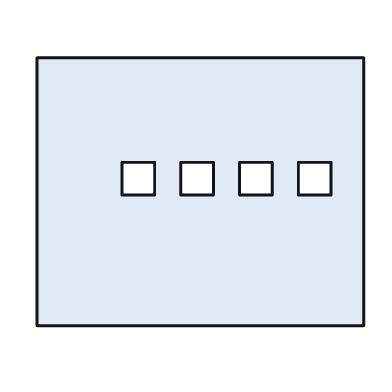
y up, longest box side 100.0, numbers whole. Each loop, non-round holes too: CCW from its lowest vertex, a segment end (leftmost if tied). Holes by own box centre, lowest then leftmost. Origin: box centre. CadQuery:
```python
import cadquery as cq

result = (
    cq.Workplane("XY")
    .moveTo(-50.0, -41.0)
    .lineTo(50.0, -41.0)
    .lineTo(50.0, 41.0)
    .lineTo(-50.0, 41.0)
    .close()
    .moveTo(-24.0, -1.0)
    .lineTo(-14.0, -1.0)
    .lineTo(-14.0, 9.0)
    .lineTo(-24.0, 9.0)
    .close()
    .moveTo(-6.0, -1.0)
    .lineTo(4.0, -1.0)
    .lineTo(4.0, 9.0)
    .lineTo(-6.0, 9.0)
    .close()
    .moveTo(12.0, -1.0)
    .lineTo(22.0, -1.0)
    .lineTo(22.0, 9.0)
    .lineTo(12.0, 9.0)
    .close()
    .moveTo(30.0, -1.0)
    .lineTo(40.0, -1.0)
    .lineTo(40.0, 9.0)
    .lineTo(30.0, 9.0)
    .close()
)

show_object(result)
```